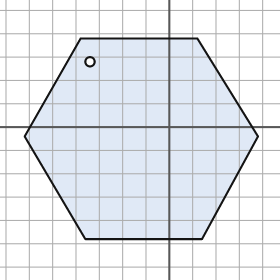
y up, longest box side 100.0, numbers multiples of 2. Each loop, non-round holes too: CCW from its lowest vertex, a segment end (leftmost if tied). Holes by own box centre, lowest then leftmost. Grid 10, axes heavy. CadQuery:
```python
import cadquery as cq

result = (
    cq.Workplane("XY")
    .moveTo(-36.0, -48.0)
    .lineTo(14.0, -48.0)
    .lineTo(38.0, -4.0)
    .lineTo(12.0, 38.0)
    .lineTo(-38.0, 38.0)
    .lineTo(-62.0, -4.0)
    .close()
    .moveTo(-34.0, 28.0)
    .circle(2.0)
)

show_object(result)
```